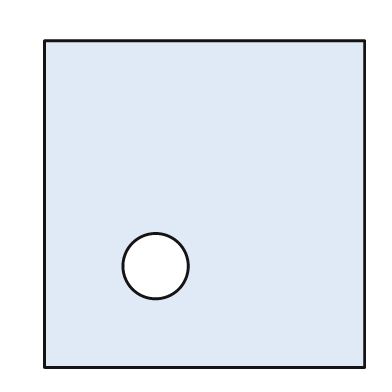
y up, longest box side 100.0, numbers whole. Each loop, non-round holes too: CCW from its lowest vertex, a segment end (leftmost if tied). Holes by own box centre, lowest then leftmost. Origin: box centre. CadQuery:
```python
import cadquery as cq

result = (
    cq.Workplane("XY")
    .moveTo(-49.0, -50.0)
    .lineTo(49.0, -50.0)
    .lineTo(49.0, 50.0)
    .lineTo(-49.0, 50.0)
    .close()
    .moveTo(-15.0, -19.0)
    .circle(10.0)
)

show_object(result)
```